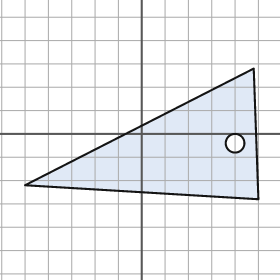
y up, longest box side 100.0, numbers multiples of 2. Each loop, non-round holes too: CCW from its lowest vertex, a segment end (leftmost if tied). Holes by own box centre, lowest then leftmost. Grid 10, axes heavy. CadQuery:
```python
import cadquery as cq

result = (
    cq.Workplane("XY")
    .moveTo(50.0, -28.0)
    .lineTo(48.0, 28.0)
    .lineTo(-50.0, -22.0)
    .close()
    .moveTo(40.0, -4.0)
    .circle(4.0)
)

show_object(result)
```